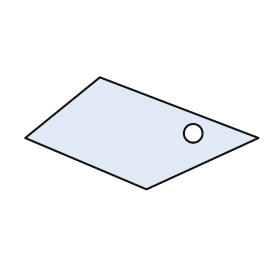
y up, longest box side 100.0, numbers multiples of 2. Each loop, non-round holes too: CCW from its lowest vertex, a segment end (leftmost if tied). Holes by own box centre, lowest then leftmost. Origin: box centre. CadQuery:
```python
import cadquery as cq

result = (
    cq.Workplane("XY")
    .moveTo(2.0, -24.0)
    .lineTo(50.0, -2.0)
    .lineTo(-18.0, 24.0)
    .lineTo(-50.0, -2.0)
    .close()
    .moveTo(22.0, 0.0)
    .circle(4.0)
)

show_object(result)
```